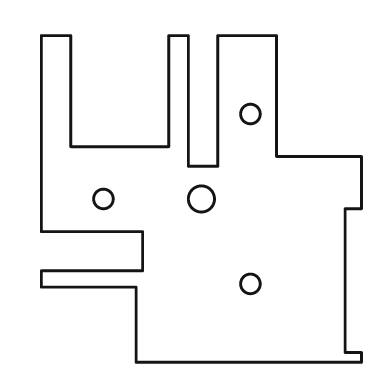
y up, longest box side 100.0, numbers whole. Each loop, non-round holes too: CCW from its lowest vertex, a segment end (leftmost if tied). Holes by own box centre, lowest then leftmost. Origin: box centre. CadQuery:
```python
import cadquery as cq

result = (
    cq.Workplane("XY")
    .moveTo(-20.0, -50.0)
    .lineTo(49.0, -50.0)
    .lineTo(49.0, -47.0)
    .lineTo(44.0, -47.0)
    .lineTo(44.0, -3.0)
    .lineTo(49.0, -3.0)
    .lineTo(49.0, 13.0)
    .lineTo(23.0, 13.0)
    .lineTo(23.0, 50.0)
    .lineTo(5.0, 50.0)
    .lineTo(5.0, 10.0)
    .lineTo(-4.0, 10.0)
    .lineTo(-4.0, 50.0)
    .lineTo(-10.0, 50.0)
    .lineTo(-10.0, 16.0)
    .lineTo(-40.0, 16.0)
    .lineTo(-40.0, 50.0)
    .lineTo(-49.0, 50.0)
    .lineTo(-49.0, -10.0)
    .lineTo(-18.0, -10.0)
    .lineTo(-18.0, -22.0)
    .lineTo(-49.0, -22.0)
    .lineTo(-49.0, -27.0)
    .lineTo(-20.0, -27.0)
    .close()
    .moveTo(15.0, -26.0)
    .circle(3.0)
    .moveTo(-30.0, 0.0)
    .circle(3.0)
    .moveTo(0.0, 0.0)
    .circle(4.0)
    .moveTo(15.0, 26.0)
    .circle(3.0)
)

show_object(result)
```